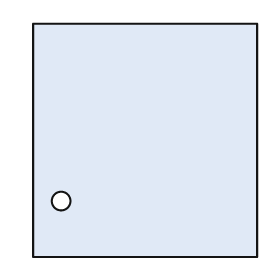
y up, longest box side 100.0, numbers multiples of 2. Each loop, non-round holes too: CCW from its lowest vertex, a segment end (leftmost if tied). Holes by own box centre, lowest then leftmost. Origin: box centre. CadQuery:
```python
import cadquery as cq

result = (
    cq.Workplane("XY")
    .moveTo(-48.0, -50.0)
    .lineTo(48.0, -50.0)
    .lineTo(48.0, 50.0)
    .lineTo(-48.0, 50.0)
    .close()
    .moveTo(-36.0, -26.0)
    .circle(4.0)
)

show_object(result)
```